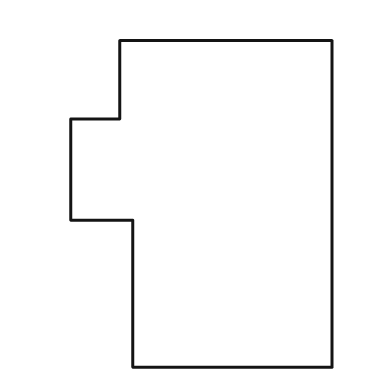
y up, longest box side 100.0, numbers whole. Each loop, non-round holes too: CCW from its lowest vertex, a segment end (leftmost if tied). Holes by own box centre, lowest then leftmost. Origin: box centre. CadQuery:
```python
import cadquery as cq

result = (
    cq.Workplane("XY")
    .moveTo(-21.0, -50.0)
    .lineTo(40.0, -50.0)
    .lineTo(40.0, 50.0)
    .lineTo(-25.0, 50.0)
    .lineTo(-25.0, 26.0)
    .lineTo(-40.0, 26.0)
    .lineTo(-40.0, -5.0)
    .lineTo(-21.0, -5.0)
    .close()
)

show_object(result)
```